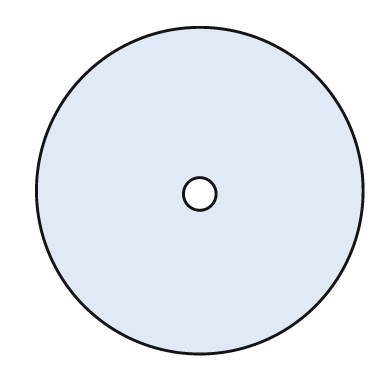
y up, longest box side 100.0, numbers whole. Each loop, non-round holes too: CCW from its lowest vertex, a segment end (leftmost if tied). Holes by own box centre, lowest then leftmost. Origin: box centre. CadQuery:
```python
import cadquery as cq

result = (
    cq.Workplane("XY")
    .moveTo(0.0, 0.0)
    .circle(50.0)
    .moveTo(0.0, -1.0)
    .circle(5.0)
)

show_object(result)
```